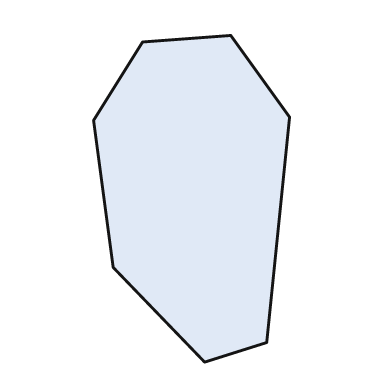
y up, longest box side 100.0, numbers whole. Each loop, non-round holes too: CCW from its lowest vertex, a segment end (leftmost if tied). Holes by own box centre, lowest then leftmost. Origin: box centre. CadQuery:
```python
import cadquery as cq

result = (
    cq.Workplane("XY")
    .moveTo(4.0, -50.0)
    .lineTo(23.0, -44.0)
    .lineTo(30.0, 25.0)
    .lineTo(12.0, 50.0)
    .lineTo(-15.0, 48.0)
    .lineTo(-30.0, 24.0)
    .lineTo(-24.0, -21.0)
    .close()
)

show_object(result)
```